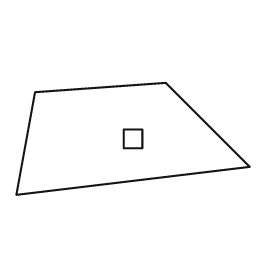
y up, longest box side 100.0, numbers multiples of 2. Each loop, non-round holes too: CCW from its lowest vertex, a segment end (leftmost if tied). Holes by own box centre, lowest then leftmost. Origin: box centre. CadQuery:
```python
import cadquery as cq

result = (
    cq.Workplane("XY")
    .moveTo(-50.0, -24.0)
    .lineTo(50.0, -12.0)
    .lineTo(14.0, 24.0)
    .lineTo(-42.0, 20.0)
    .close()
    .moveTo(-4.0, -4.0)
    .lineTo(4.0, -4.0)
    .lineTo(4.0, 4.0)
    .lineTo(-4.0, 4.0)
    .close()
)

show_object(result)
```